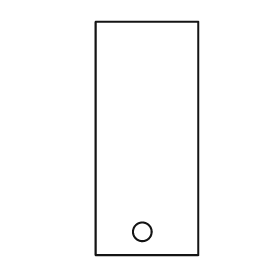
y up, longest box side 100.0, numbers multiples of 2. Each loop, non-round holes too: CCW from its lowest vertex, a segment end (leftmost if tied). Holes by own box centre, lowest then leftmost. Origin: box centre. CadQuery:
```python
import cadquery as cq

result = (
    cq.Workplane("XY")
    .moveTo(-22.0, -50.0)
    .lineTo(22.0, -50.0)
    .lineTo(22.0, 50.0)
    .lineTo(-22.0, 50.0)
    .close()
    .moveTo(-2.0, -40.0)
    .circle(4.0)
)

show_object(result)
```